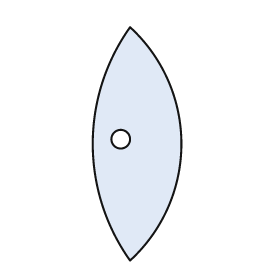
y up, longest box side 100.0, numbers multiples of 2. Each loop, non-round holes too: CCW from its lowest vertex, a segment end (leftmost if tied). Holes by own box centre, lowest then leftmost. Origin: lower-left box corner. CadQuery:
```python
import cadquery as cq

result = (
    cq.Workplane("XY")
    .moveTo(16.0, 0.0)
    .threePointArc((38.0, 50.0), (16.0, 100.0))
    .threePointArc((0.0, 50.0), (16.0, 0.0))
    .close()
    .moveTo(12.0, 52.0)
    .circle(4.0)
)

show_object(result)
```